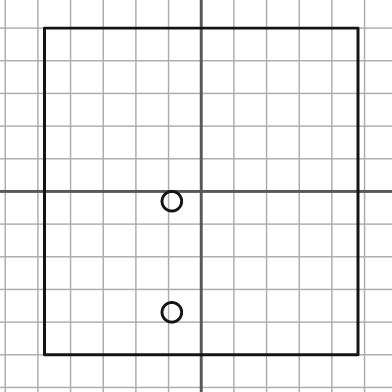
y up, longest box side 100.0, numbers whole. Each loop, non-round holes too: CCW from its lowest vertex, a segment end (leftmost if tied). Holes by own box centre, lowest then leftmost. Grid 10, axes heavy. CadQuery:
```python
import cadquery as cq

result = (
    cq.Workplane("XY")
    .moveTo(-48.0, -50.0)
    .lineTo(48.0, -50.0)
    .lineTo(48.0, 50.0)
    .lineTo(-48.0, 50.0)
    .close()
    .moveTo(-9.0, -37.0)
    .circle(3.0)
    .moveTo(-9.0, -3.0)
    .circle(3.0)
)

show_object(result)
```